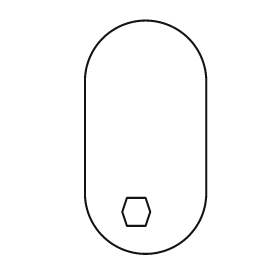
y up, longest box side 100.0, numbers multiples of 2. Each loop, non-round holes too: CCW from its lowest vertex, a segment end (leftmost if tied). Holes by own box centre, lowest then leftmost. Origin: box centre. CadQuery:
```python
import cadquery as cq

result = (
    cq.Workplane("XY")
    .moveTo(-26.0, -24.0)
    .threePointArc((0.0, -50.0), (26.0, -24.0))
    .lineTo(26.0, 24.0)
    .threePointArc((0.0, 50.0), (-26.0, 24.0))
    .close()
    .moveTo(-8.0, -38.0)
    .lineTo(0.0, -38.0)
    .lineTo(2.0, -32.0)
    .lineTo(0.0, -26.0)
    .lineTo(-8.0, -26.0)
    .lineTo(-10.0, -32.0)
    .close()
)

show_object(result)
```